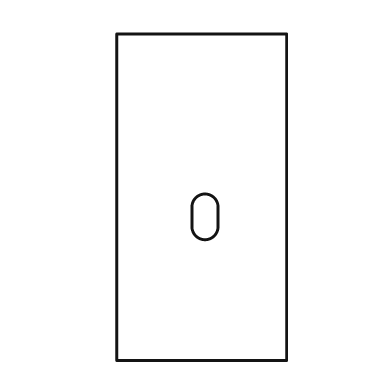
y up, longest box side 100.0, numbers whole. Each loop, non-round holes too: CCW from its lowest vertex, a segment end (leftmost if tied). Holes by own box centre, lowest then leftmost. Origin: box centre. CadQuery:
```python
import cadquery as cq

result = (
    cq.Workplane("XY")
    .moveTo(-26.0, -50.0)
    .lineTo(26.0, -50.0)
    .lineTo(26.0, 50.0)
    .lineTo(-26.0, 50.0)
    .close()
    .moveTo(-3.0, -9.0)
    .threePointArc((1.0, -13.0), (5.0, -9.0))
    .lineTo(5.0, -3.0)
    .threePointArc((1.0, 1.0), (-3.0, -3.0))
    .close()
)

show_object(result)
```